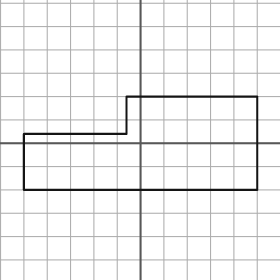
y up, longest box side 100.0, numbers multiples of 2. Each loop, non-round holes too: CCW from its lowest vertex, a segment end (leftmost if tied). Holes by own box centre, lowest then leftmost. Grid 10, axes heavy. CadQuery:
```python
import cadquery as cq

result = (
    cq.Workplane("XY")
    .moveTo(-50.0, -20.0)
    .lineTo(50.0, -20.0)
    .lineTo(50.0, 20.0)
    .lineTo(-6.0, 20.0)
    .lineTo(-6.0, 4.0)
    .lineTo(-50.0, 4.0)
    .close()
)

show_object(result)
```